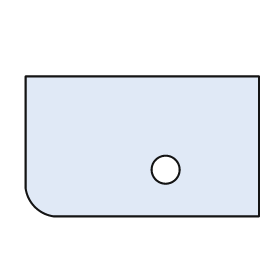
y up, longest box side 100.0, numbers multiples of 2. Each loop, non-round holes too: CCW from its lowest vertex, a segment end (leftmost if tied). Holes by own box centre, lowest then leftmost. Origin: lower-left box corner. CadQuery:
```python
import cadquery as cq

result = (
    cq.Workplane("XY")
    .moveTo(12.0, 0.0)
    .lineTo(100.0, 0.0)
    .lineTo(100.0, 60.0)
    .lineTo(0.0, 60.0)
    .lineTo(0.0, 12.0)
    .threePointArc((4.0, 4.0), (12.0, 0.0))
    .close()
    .moveTo(60.0, 20.0)
    .circle(6.0)
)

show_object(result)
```